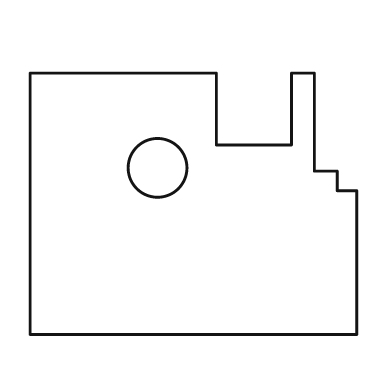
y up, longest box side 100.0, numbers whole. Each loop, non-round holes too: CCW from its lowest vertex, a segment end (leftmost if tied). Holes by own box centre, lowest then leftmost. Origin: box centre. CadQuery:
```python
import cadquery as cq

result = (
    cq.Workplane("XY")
    .moveTo(-50.0, -40.0)
    .lineTo(50.0, -40.0)
    .lineTo(50.0, 4.0)
    .lineTo(44.0, 4.0)
    .lineTo(44.0, 10.0)
    .lineTo(37.0, 10.0)
    .lineTo(37.0, 40.0)
    .lineTo(30.0, 40.0)
    .lineTo(30.0, 18.0)
    .lineTo(7.0, 18.0)
    .lineTo(7.0, 40.0)
    .lineTo(-50.0, 40.0)
    .close()
    .moveTo(-11.0, 11.0)
    .circle(9.0)
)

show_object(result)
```